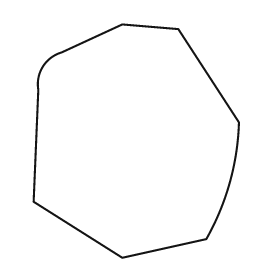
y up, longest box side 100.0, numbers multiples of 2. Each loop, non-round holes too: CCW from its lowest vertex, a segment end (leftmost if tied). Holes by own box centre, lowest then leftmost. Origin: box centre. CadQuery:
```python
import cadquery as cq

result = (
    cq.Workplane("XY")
    .moveTo(-6.0, -50.0)
    .lineTo(30.0, -42.0)
    .threePointArc((40.0, -18.0), (44.0, 8.0))
    .lineTo(18.0, 48.0)
    .lineTo(-6.0, 50.0)
    .lineTo(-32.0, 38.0)
    .threePointArc((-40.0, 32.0), (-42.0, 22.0))
    .lineTo(-44.0, -26.0)
    .close()
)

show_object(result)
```